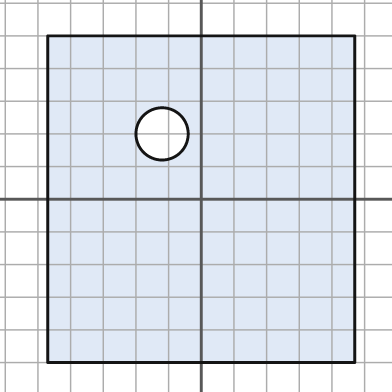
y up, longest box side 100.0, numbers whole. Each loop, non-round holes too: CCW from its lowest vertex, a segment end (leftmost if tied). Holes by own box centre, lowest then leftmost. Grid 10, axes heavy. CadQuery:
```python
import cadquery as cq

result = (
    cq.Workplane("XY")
    .moveTo(-47.0, -50.0)
    .lineTo(47.0, -50.0)
    .lineTo(47.0, 50.0)
    .lineTo(-47.0, 50.0)
    .close()
    .moveTo(-12.0, 20.0)
    .circle(8.0)
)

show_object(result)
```